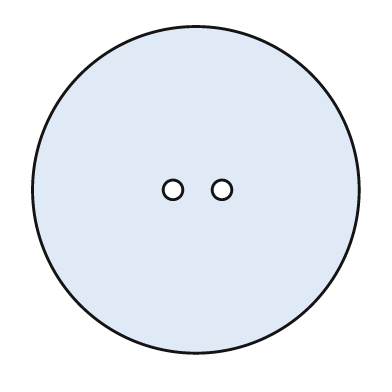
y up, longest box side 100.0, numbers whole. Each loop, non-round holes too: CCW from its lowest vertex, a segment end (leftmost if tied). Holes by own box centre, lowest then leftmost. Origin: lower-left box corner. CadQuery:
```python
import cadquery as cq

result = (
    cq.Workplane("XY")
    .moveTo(50.0, 50.0)
    .circle(50.0)
    .moveTo(43.0, 50.0)
    .circle(3.0)
    .moveTo(58.0, 50.0)
    .circle(3.0)
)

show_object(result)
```